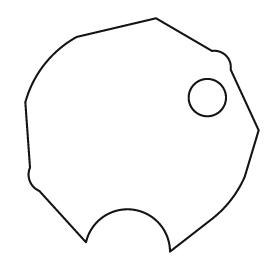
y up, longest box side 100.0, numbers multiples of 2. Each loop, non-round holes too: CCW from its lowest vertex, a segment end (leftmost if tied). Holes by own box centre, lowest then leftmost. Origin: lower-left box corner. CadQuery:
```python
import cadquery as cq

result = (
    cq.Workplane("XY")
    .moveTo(62.0, 0.0)
    .lineTo(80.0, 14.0)
    .threePointArc((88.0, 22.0), (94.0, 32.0))
    .lineTo(100.0, 52.0)
    .lineTo(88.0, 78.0)
    .threePointArc((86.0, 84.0), (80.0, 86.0))
    .lineTo(56.0, 100.0)
    .lineTo(22.0, 92.0)
    .threePointArc((8.0, 80.0), (0.0, 64.0))
    .lineTo(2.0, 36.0)
    .threePointArc((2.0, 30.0), (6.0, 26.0))
    .lineTo(26.0, 4.0)
    .threePointArc((46.0, 18.0), (62.0, 0.0))
    .close()
    .moveTo(78.0, 66.0)
    .circle(8.0)
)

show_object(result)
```